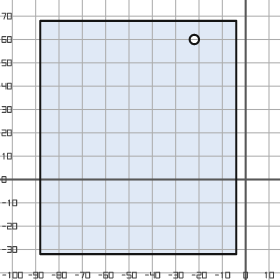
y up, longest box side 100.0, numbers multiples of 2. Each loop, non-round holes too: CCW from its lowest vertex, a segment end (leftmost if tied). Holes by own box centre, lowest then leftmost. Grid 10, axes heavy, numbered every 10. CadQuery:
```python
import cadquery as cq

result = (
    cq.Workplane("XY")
    .moveTo(-88.0, -32.0)
    .lineTo(-4.0, -32.0)
    .lineTo(-4.0, 68.0)
    .lineTo(-88.0, 68.0)
    .close()
    .moveTo(-22.0, 60.0)
    .circle(2.0)
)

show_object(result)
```